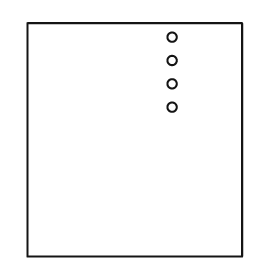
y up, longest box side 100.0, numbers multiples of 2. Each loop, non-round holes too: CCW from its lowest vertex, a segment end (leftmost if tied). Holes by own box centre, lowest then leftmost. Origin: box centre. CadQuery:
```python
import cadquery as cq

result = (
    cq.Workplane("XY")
    .moveTo(-46.0, -50.0)
    .lineTo(46.0, -50.0)
    .lineTo(46.0, 50.0)
    .lineTo(-46.0, 50.0)
    .close()
    .moveTo(16.0, 14.0)
    .circle(2.0)
    .moveTo(16.0, 24.0)
    .circle(2.0)
    .moveTo(16.0, 34.0)
    .circle(2.0)
    .moveTo(16.0, 44.0)
    .circle(2.0)
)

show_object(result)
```